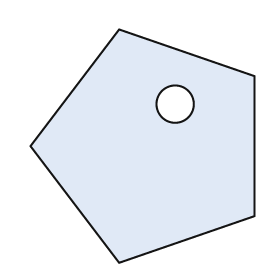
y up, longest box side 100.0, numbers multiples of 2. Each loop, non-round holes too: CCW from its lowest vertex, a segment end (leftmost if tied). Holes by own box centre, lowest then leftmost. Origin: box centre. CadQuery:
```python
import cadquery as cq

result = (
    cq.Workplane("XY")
    .moveTo(-10.0, -50.0)
    .lineTo(48.0, -30.0)
    .lineTo(48.0, 30.0)
    .lineTo(-10.0, 50.0)
    .lineTo(-48.0, 0.0)
    .close()
    .moveTo(14.0, 18.0)
    .circle(8.0)
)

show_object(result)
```